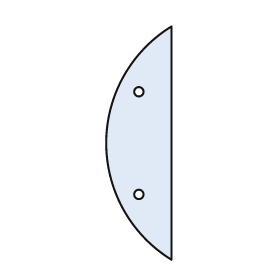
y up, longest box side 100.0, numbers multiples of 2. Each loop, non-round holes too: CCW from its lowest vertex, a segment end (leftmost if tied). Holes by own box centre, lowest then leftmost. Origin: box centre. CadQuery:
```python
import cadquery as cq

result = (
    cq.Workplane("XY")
    .moveTo(14.0, -50.0)
    .lineTo(14.0, 50.0)
    .threePointArc((-14.0, 0.0), (14.0, -50.0))
    .close()
    .moveTo(0.0, -22.0)
    .circle(2.0)
    .moveTo(0.0, 22.0)
    .circle(2.0)
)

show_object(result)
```